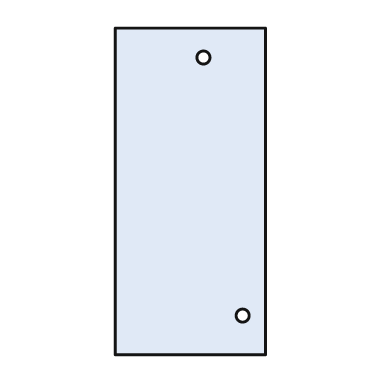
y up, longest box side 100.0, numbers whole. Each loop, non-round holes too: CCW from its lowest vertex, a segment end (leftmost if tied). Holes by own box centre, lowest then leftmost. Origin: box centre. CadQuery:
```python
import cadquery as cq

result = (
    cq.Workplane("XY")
    .moveTo(-23.0, -50.0)
    .lineTo(23.0, -50.0)
    .lineTo(23.0, 50.0)
    .lineTo(-23.0, 50.0)
    .close()
    .moveTo(16.0, -38.0)
    .circle(2.0)
    .moveTo(4.0, 41.0)
    .circle(2.0)
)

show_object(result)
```